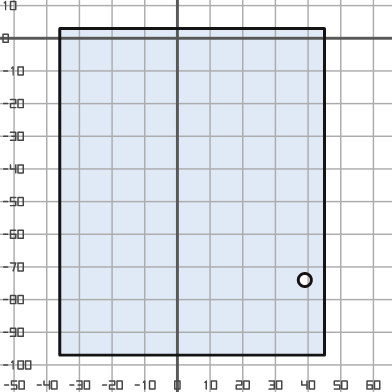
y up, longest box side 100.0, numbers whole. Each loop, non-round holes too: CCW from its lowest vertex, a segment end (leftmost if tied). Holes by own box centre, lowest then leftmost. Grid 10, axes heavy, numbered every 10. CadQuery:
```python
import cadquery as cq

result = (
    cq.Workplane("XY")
    .moveTo(-36.0, -97.0)
    .lineTo(45.0, -97.0)
    .lineTo(45.0, 3.0)
    .lineTo(-36.0, 3.0)
    .close()
    .moveTo(39.0, -74.0)
    .circle(2.0)
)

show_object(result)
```